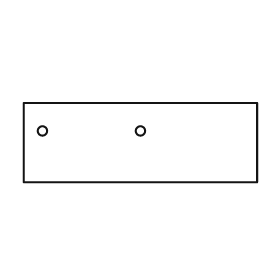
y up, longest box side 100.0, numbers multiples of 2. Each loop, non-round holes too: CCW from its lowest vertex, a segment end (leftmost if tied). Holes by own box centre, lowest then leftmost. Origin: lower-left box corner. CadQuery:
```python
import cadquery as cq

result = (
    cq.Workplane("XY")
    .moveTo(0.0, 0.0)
    .lineTo(100.0, 0.0)
    .lineTo(100.0, 34.0)
    .lineTo(0.0, 34.0)
    .close()
    .moveTo(8.0, 22.0)
    .circle(2.0)
    .moveTo(50.0, 22.0)
    .circle(2.0)
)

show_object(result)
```